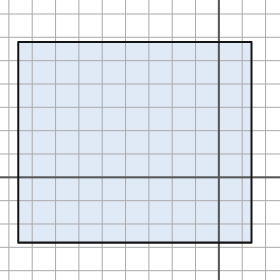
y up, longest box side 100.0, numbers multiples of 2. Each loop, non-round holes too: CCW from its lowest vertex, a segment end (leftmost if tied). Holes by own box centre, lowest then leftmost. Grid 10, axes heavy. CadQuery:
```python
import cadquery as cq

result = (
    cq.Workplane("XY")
    .moveTo(-86.0, -28.0)
    .lineTo(14.0, -28.0)
    .lineTo(14.0, 58.0)
    .lineTo(-86.0, 58.0)
    .close()
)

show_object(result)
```